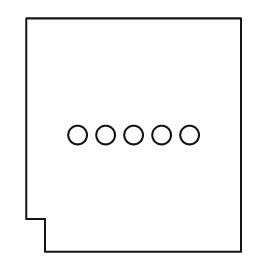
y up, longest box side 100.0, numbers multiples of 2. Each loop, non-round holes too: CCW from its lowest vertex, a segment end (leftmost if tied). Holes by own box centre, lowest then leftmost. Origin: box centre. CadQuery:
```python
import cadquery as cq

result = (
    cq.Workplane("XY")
    .moveTo(-38.0, -50.0)
    .lineTo(46.0, -50.0)
    .lineTo(46.0, 50.0)
    .lineTo(-46.0, 50.0)
    .lineTo(-46.0, -36.0)
    .lineTo(-38.0, -36.0)
    .close()
    .moveTo(-24.0, 0.0)
    .circle(4.0)
    .moveTo(-12.0, 0.0)
    .circle(4.0)
    .moveTo(0.0, 0.0)
    .circle(4.0)
    .moveTo(12.0, 0.0)
    .circle(4.0)
    .moveTo(24.0, 0.0)
    .circle(4.0)
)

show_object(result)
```